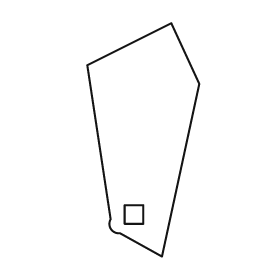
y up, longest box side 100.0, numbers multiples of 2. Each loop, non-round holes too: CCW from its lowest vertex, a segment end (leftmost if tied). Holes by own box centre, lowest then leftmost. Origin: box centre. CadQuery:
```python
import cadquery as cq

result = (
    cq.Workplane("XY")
    .moveTo(8.0, -50.0)
    .lineTo(24.0, 24.0)
    .lineTo(12.0, 50.0)
    .lineTo(-24.0, 32.0)
    .lineTo(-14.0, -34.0)
    .threePointArc((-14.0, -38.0), (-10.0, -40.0))
    .close()
    .moveTo(-8.0, -36.0)
    .lineTo(0.0, -36.0)
    .lineTo(0.0, -28.0)
    .lineTo(-8.0, -28.0)
    .close()
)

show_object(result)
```